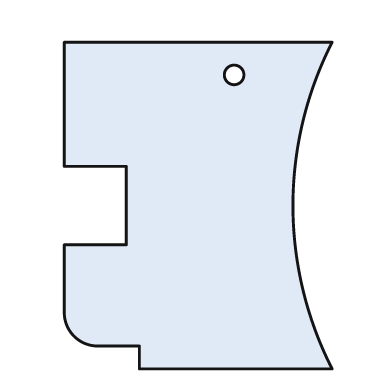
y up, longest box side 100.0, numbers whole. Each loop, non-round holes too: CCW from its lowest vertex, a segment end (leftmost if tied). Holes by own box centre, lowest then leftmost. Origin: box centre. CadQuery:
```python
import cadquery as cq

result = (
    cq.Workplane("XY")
    .moveTo(-18.0, -50.0)
    .lineTo(41.0, -50.0)
    .threePointArc((29.0, 0.0), (41.0, 50.0))
    .lineTo(-41.0, 50.0)
    .lineTo(-41.0, 12.0)
    .lineTo(-22.0, 12.0)
    .lineTo(-22.0, -12.0)
    .lineTo(-41.0, -12.0)
    .lineTo(-41.0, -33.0)
    .threePointArc((-38.0, -40.0), (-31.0, -43.0))
    .lineTo(-18.0, -43.0)
    .close()
    .moveTo(11.0, 40.0)
    .circle(3.0)
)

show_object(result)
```